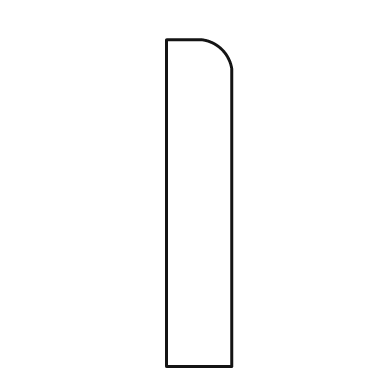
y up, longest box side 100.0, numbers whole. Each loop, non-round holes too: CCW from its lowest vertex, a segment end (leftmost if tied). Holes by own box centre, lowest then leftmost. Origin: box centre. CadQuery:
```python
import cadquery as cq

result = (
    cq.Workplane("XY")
    .moveTo(-10.0, -50.0)
    .lineTo(10.0, -50.0)
    .lineTo(10.0, 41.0)
    .threePointArc((7.0, 47.0), (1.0, 50.0))
    .lineTo(-10.0, 50.0)
    .close()
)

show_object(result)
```